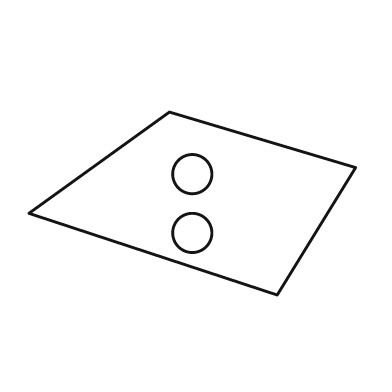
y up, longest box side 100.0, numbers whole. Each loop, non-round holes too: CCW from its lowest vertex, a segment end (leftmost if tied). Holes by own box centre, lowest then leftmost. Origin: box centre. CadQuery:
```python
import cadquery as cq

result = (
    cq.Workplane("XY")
    .moveTo(26.0, -28.0)
    .lineTo(50.0, 11.0)
    .lineTo(-7.0, 28.0)
    .lineTo(-50.0, -3.0)
    .close()
    .moveTo(0.0, -9.0)
    .circle(6.0)
    .moveTo(0.0, 9.0)
    .circle(6.0)
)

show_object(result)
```